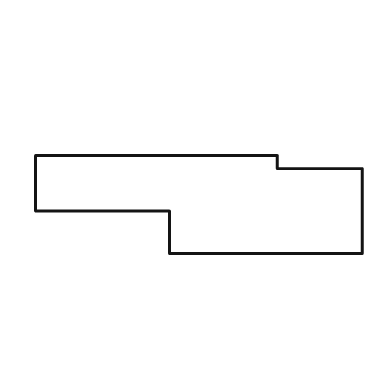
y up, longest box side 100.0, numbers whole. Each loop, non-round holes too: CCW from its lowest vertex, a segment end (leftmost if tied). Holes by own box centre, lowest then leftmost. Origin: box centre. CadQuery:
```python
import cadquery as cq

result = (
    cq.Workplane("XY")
    .moveTo(-9.0, -15.0)
    .lineTo(50.0, -15.0)
    .lineTo(50.0, 11.0)
    .lineTo(24.0, 11.0)
    .lineTo(24.0, 15.0)
    .lineTo(-50.0, 15.0)
    .lineTo(-50.0, -2.0)
    .lineTo(-9.0, -2.0)
    .close()
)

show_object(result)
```